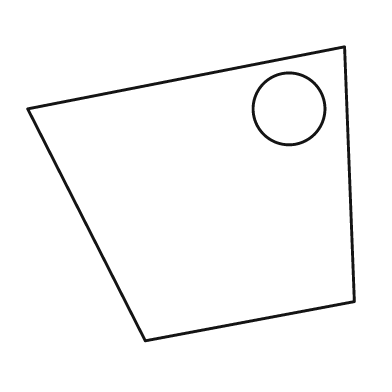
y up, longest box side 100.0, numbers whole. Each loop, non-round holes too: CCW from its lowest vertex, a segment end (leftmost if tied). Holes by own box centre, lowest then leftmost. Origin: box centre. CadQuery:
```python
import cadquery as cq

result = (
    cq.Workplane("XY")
    .moveTo(-14.0, -45.0)
    .lineTo(50.0, -33.0)
    .lineTo(47.0, 45.0)
    .lineTo(-50.0, 26.0)
    .close()
    .moveTo(30.0, 26.0)
    .circle(11.0)
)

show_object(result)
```